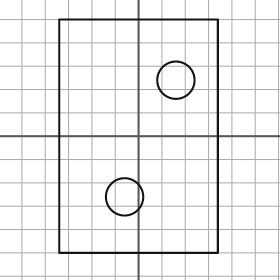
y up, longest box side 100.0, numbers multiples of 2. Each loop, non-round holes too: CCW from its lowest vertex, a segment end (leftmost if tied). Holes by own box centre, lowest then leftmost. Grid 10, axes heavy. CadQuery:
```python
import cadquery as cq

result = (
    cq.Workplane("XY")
    .moveTo(-34.0, -50.0)
    .lineTo(34.0, -50.0)
    .lineTo(34.0, 50.0)
    .lineTo(-34.0, 50.0)
    .close()
    .moveTo(-6.0, -26.0)
    .circle(8.0)
    .moveTo(16.0, 24.0)
    .circle(8.0)
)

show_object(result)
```